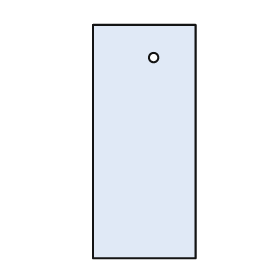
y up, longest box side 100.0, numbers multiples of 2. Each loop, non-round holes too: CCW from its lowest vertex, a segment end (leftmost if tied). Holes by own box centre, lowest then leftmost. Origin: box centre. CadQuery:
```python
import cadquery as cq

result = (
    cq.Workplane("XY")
    .moveTo(-22.0, -50.0)
    .lineTo(22.0, -50.0)
    .lineTo(22.0, 50.0)
    .lineTo(-22.0, 50.0)
    .close()
    .moveTo(4.0, 36.0)
    .circle(2.0)
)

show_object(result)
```